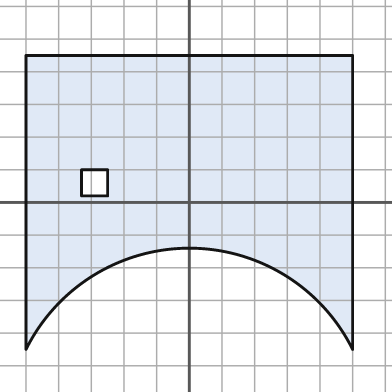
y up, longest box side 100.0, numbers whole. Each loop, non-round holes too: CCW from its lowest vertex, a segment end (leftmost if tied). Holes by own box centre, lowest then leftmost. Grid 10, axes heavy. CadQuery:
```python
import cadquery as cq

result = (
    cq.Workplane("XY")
    .moveTo(-50.0, -45.0)
    .threePointArc((0.0, -14.0), (50.0, -45.0))
    .lineTo(50.0, 45.0)
    .lineTo(-50.0, 45.0)
    .close()
    .moveTo(-33.0, 2.0)
    .lineTo(-25.0, 2.0)
    .lineTo(-25.0, 10.0)
    .lineTo(-33.0, 10.0)
    .close()
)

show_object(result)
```